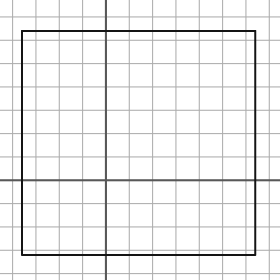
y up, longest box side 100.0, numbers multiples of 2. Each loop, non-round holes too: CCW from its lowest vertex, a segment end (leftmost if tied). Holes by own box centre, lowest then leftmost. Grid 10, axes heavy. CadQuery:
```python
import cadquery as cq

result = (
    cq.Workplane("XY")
    .moveTo(-36.0, -32.0)
    .lineTo(64.0, -32.0)
    .lineTo(64.0, 64.0)
    .lineTo(-36.0, 64.0)
    .close()
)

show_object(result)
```